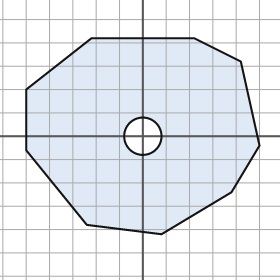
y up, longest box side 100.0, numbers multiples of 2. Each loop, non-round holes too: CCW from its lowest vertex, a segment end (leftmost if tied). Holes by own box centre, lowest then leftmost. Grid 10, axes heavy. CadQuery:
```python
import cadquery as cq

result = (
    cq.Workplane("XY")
    .moveTo(8.0, -42.0)
    .lineTo(38.0, -24.0)
    .lineTo(50.0, -4.0)
    .lineTo(42.0, 32.0)
    .lineTo(22.0, 42.0)
    .lineTo(-22.0, 42.0)
    .lineTo(-50.0, 20.0)
    .lineTo(-50.0, -6.0)
    .lineTo(-24.0, -38.0)
    .close()
    .moveTo(0.0, 0.0)
    .circle(8.0)
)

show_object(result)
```